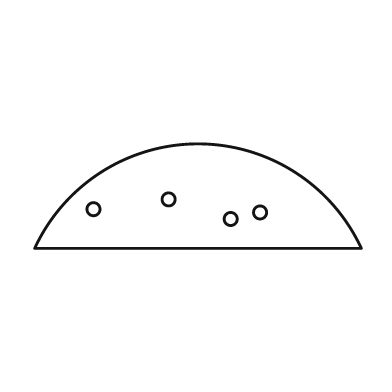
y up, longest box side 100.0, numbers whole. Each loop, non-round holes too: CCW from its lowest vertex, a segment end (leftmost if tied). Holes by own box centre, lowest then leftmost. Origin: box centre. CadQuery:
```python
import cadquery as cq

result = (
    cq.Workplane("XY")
    .moveTo(-50.0, -16.0)
    .lineTo(50.0, -16.0)
    .threePointArc((0.0, 16.0), (-50.0, -16.0))
    .close()
    .moveTo(10.0, -7.0)
    .circle(2.0)
    .moveTo(19.0, -5.0)
    .circle(2.0)
    .moveTo(-32.0, -4.0)
    .circle(2.0)
    .moveTo(-9.0, -1.0)
    .circle(2.0)
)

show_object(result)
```